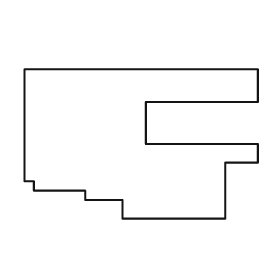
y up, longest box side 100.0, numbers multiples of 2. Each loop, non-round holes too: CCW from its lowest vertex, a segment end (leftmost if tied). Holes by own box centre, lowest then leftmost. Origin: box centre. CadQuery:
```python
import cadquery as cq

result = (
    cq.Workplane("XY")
    .moveTo(-8.0, -32.0)
    .lineTo(36.0, -32.0)
    .lineTo(36.0, -8.0)
    .lineTo(50.0, -8.0)
    .lineTo(50.0, 0.0)
    .lineTo(2.0, 0.0)
    .lineTo(2.0, 18.0)
    .lineTo(50.0, 18.0)
    .lineTo(50.0, 32.0)
    .lineTo(-50.0, 32.0)
    .lineTo(-50.0, -16.0)
    .lineTo(-46.0, -16.0)
    .lineTo(-46.0, -20.0)
    .lineTo(-24.0, -20.0)
    .lineTo(-24.0, -24.0)
    .lineTo(-8.0, -24.0)
    .close()
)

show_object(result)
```